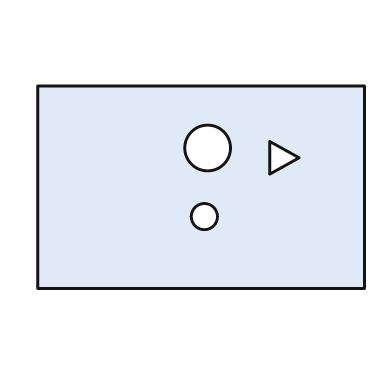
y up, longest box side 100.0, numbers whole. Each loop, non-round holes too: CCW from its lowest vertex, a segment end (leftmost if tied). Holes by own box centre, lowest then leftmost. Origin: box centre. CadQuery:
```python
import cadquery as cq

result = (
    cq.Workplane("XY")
    .moveTo(-50.0, -31.0)
    .lineTo(50.0, -31.0)
    .lineTo(50.0, 31.0)
    .lineTo(-50.0, 31.0)
    .close()
    .moveTo(1.0, -9.0)
    .circle(4.0)
    .moveTo(21.0, 4.0)
    .lineTo(30.0, 9.0)
    .lineTo(21.0, 14.0)
    .close()
    .moveTo(2.0, 12.0)
    .circle(7.0)
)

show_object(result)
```